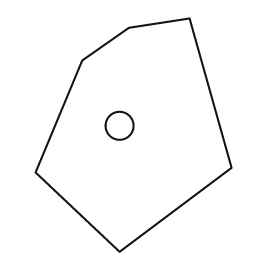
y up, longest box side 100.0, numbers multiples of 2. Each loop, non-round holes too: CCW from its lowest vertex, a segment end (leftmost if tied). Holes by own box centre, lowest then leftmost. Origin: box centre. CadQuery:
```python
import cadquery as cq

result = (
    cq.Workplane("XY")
    .moveTo(-6.0, -50.0)
    .lineTo(42.0, -14.0)
    .lineTo(24.0, 50.0)
    .lineTo(-2.0, 46.0)
    .lineTo(-22.0, 32.0)
    .lineTo(-42.0, -16.0)
    .close()
    .moveTo(-6.0, 4.0)
    .circle(6.0)
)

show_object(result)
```